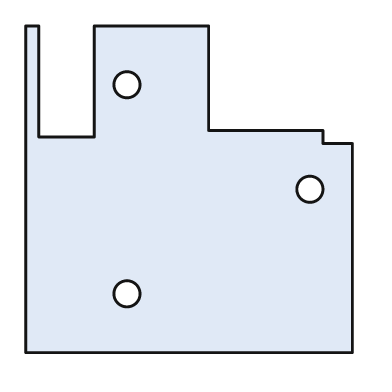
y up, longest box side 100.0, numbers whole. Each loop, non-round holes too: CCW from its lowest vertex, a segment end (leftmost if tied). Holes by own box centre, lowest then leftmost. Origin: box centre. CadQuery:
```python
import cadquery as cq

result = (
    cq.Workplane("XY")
    .moveTo(-50.0, -50.0)
    .lineTo(50.0, -50.0)
    .lineTo(50.0, 14.0)
    .lineTo(41.0, 14.0)
    .lineTo(41.0, 18.0)
    .lineTo(6.0, 18.0)
    .lineTo(6.0, 50.0)
    .lineTo(-29.0, 50.0)
    .lineTo(-29.0, 16.0)
    .lineTo(-46.0, 16.0)
    .lineTo(-46.0, 50.0)
    .lineTo(-50.0, 50.0)
    .close()
    .moveTo(-19.0, -32.0)
    .circle(4.0)
    .moveTo(37.0, 0.0)
    .circle(4.0)
    .moveTo(-19.0, 32.0)
    .circle(4.0)
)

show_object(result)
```